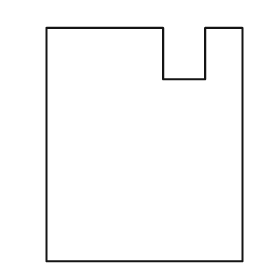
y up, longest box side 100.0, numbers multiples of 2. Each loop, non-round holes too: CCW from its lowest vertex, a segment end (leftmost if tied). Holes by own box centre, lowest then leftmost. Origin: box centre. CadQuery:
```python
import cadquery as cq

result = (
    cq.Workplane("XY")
    .moveTo(-42.0, -50.0)
    .lineTo(42.0, -50.0)
    .lineTo(42.0, 50.0)
    .lineTo(26.0, 50.0)
    .lineTo(26.0, 28.0)
    .lineTo(8.0, 28.0)
    .lineTo(8.0, 50.0)
    .lineTo(-42.0, 50.0)
    .close()
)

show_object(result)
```